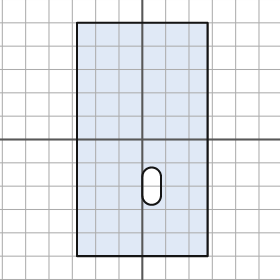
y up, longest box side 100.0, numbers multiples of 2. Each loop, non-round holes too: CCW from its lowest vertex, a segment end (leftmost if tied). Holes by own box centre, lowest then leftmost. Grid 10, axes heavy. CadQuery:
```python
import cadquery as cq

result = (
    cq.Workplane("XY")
    .moveTo(-28.0, -50.0)
    .lineTo(28.0, -50.0)
    .lineTo(28.0, 50.0)
    .lineTo(-28.0, 50.0)
    .close()
    .moveTo(0.0, -24.0)
    .threePointArc((4.0, -28.0), (8.0, -24.0))
    .lineTo(8.0, -16.0)
    .threePointArc((4.0, -12.0), (0.0, -16.0))
    .close()
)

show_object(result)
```